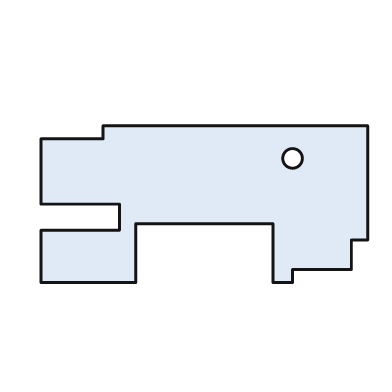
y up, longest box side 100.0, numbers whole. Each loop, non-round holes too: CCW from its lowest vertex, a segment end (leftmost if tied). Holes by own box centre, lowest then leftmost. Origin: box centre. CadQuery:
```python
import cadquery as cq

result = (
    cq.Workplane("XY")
    .moveTo(-50.0, -24.0)
    .lineTo(-21.0, -24.0)
    .lineTo(-21.0, -6.0)
    .lineTo(21.0, -6.0)
    .lineTo(21.0, -24.0)
    .lineTo(27.0, -24.0)
    .lineTo(27.0, -20.0)
    .lineTo(45.0, -20.0)
    .lineTo(45.0, -11.0)
    .lineTo(50.0, -11.0)
    .lineTo(50.0, 24.0)
    .lineTo(-31.0, 24.0)
    .lineTo(-31.0, 20.0)
    .lineTo(-50.0, 20.0)
    .lineTo(-50.0, 0.0)
    .lineTo(-26.0, 0.0)
    .lineTo(-26.0, -8.0)
    .lineTo(-50.0, -8.0)
    .close()
    .moveTo(27.0, 14.0)
    .circle(3.0)
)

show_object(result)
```